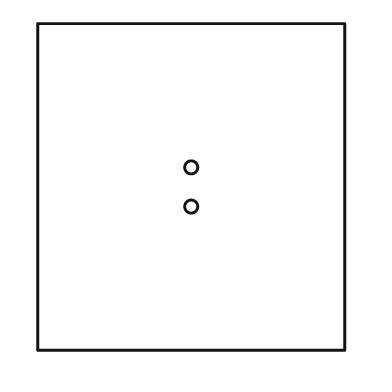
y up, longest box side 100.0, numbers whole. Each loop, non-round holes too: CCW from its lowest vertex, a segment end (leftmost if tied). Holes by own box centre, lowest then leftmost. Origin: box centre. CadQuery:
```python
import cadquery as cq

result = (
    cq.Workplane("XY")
    .moveTo(-47.0, -50.0)
    .lineTo(47.0, -50.0)
    .lineTo(47.0, 50.0)
    .lineTo(-47.0, 50.0)
    .close()
    .moveTo(0.0, -6.0)
    .circle(2.0)
    .moveTo(0.0, 6.0)
    .circle(2.0)
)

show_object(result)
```